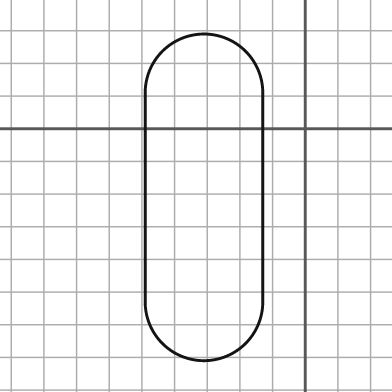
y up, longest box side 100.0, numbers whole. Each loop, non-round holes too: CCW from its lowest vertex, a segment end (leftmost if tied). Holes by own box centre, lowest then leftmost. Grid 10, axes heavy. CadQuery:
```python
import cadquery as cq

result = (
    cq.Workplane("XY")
    .moveTo(-49.0, -53.0)
    .threePointArc((-31.0, -71.0), (-13.0, -53.0))
    .lineTo(-13.0, 11.0)
    .threePointArc((-31.0, 29.0), (-49.0, 11.0))
    .close()
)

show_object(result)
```